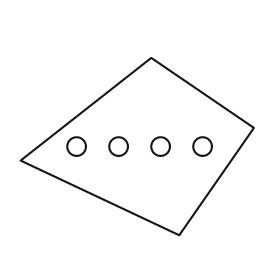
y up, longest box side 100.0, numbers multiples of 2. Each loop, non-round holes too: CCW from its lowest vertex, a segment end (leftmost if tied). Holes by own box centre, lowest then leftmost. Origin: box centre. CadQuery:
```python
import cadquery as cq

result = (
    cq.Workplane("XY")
    .moveTo(18.0, -38.0)
    .lineTo(50.0, 8.0)
    .lineTo(6.0, 38.0)
    .lineTo(-50.0, -6.0)
    .close()
    .moveTo(-26.0, 0.0)
    .circle(4.0)
    .moveTo(-8.0, 0.0)
    .circle(4.0)
    .moveTo(10.0, 0.0)
    .circle(4.0)
    .moveTo(28.0, 0.0)
    .circle(4.0)
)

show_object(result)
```